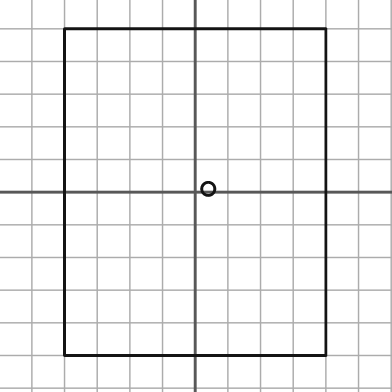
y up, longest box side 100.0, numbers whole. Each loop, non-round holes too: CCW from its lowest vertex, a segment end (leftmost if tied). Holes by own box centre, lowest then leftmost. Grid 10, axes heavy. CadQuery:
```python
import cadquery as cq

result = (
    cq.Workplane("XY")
    .moveTo(-40.0, -50.0)
    .lineTo(40.0, -50.0)
    .lineTo(40.0, 50.0)
    .lineTo(-40.0, 50.0)
    .close()
    .moveTo(4.0, 1.0)
    .circle(2.0)
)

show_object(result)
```